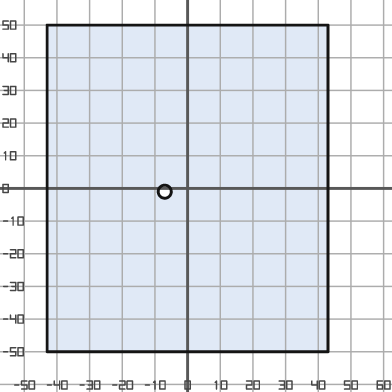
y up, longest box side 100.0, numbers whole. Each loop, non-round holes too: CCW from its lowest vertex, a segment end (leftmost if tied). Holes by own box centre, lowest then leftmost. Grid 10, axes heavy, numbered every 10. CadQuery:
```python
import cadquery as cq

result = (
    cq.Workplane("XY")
    .moveTo(-43.0, -50.0)
    .lineTo(43.0, -50.0)
    .lineTo(43.0, 50.0)
    .lineTo(-43.0, 50.0)
    .close()
    .moveTo(-7.0, -1.0)
    .circle(2.0)
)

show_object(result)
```